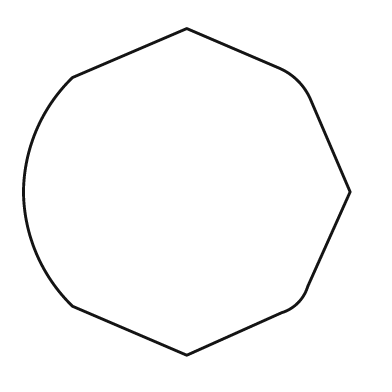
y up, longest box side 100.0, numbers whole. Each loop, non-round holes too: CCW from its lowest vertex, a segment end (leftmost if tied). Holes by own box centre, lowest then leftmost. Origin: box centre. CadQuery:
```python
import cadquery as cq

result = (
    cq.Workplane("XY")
    .moveTo(0.0, -50.0)
    .lineTo(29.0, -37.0)
    .threePointArc((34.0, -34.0), (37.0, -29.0))
    .lineTo(50.0, 0.0)
    .lineTo(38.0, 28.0)
    .threePointArc((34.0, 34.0), (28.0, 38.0))
    .lineTo(0.0, 50.0)
    .lineTo(-35.0, 35.0)
    .threePointArc((-46.0, 19.0), (-50.0, 0.0))
    .threePointArc((-46.0, -19.0), (-35.0, -35.0))
    .close()
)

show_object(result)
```